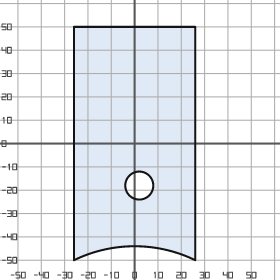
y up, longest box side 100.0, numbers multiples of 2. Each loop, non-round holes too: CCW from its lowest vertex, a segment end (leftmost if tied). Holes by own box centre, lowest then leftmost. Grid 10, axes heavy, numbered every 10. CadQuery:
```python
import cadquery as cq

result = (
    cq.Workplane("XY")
    .moveTo(-26.0, -50.0)
    .threePointArc((0.0, -44.0), (26.0, -50.0))
    .lineTo(26.0, 50.0)
    .lineTo(-26.0, 50.0)
    .close()
    .moveTo(2.0, -18.0)
    .circle(6.0)
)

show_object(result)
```